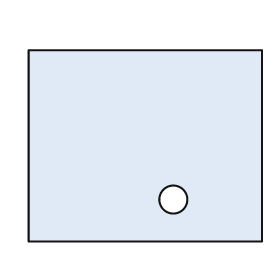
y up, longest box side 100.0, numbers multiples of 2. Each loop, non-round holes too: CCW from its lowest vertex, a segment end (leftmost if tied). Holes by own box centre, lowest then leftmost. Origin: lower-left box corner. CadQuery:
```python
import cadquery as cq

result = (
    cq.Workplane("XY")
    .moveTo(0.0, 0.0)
    .lineTo(100.0, 0.0)
    .lineTo(100.0, 82.0)
    .lineTo(0.0, 82.0)
    .close()
    .moveTo(62.0, 18.0)
    .circle(6.0)
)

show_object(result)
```